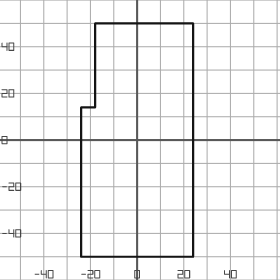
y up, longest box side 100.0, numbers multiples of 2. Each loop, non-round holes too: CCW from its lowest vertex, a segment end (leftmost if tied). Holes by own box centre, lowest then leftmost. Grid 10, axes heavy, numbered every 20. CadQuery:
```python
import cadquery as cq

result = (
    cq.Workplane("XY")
    .moveTo(-24.0, -50.0)
    .lineTo(24.0, -50.0)
    .lineTo(24.0, 50.0)
    .lineTo(-18.0, 50.0)
    .lineTo(-18.0, 14.0)
    .lineTo(-24.0, 14.0)
    .close()
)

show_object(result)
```